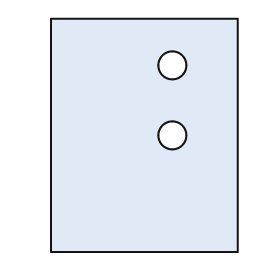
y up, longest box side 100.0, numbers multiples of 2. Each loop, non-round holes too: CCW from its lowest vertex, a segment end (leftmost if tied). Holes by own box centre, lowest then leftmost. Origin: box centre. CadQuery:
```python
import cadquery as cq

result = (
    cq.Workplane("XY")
    .moveTo(-40.0, -50.0)
    .lineTo(40.0, -50.0)
    .lineTo(40.0, 50.0)
    .lineTo(-40.0, 50.0)
    .close()
    .moveTo(12.0, 0.0)
    .circle(6.0)
    .moveTo(12.0, 30.0)
    .circle(6.0)
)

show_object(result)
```